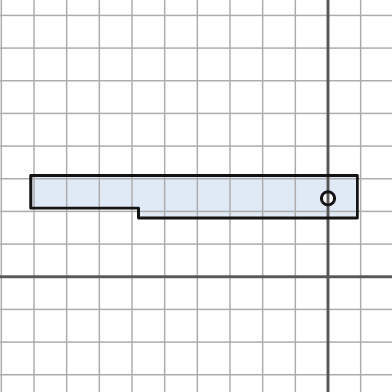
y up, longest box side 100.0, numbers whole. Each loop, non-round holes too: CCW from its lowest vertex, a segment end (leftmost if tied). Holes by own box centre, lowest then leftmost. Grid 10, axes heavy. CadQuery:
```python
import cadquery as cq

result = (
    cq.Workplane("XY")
    .moveTo(-58.0, 18.0)
    .lineTo(9.0, 18.0)
    .lineTo(9.0, 31.0)
    .lineTo(-91.0, 31.0)
    .lineTo(-91.0, 21.0)
    .lineTo(-58.0, 21.0)
    .close()
    .moveTo(0.0, 24.0)
    .circle(2.0)
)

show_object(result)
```